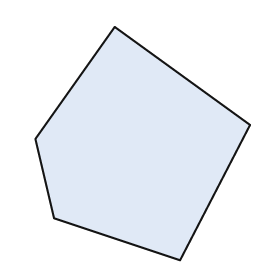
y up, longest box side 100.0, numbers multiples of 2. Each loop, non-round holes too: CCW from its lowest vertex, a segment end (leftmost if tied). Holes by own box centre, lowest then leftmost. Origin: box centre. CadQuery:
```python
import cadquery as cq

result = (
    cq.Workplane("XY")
    .moveTo(16.0, -50.0)
    .lineTo(46.0, 8.0)
    .lineTo(-12.0, 50.0)
    .lineTo(-46.0, 2.0)
    .lineTo(-38.0, -32.0)
    .close()
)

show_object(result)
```